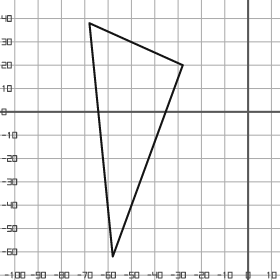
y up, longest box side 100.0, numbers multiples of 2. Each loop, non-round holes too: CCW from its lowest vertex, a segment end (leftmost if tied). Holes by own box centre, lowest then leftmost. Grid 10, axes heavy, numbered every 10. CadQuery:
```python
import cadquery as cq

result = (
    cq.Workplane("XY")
    .moveTo(-58.0, -62.0)
    .lineTo(-28.0, 20.0)
    .lineTo(-68.0, 38.0)
    .close()
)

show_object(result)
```